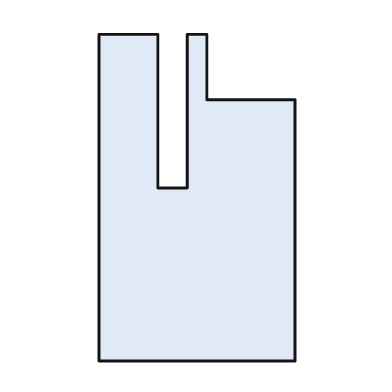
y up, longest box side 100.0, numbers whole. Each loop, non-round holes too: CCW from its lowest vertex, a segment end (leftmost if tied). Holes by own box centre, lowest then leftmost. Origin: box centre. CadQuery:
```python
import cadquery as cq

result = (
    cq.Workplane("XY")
    .moveTo(-30.0, -50.0)
    .lineTo(30.0, -50.0)
    .lineTo(30.0, 30.0)
    .lineTo(3.0, 30.0)
    .lineTo(3.0, 50.0)
    .lineTo(-3.0, 50.0)
    .lineTo(-3.0, 3.0)
    .lineTo(-12.0, 3.0)
    .lineTo(-12.0, 50.0)
    .lineTo(-30.0, 50.0)
    .close()
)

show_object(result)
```